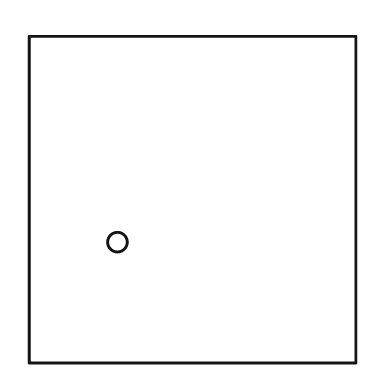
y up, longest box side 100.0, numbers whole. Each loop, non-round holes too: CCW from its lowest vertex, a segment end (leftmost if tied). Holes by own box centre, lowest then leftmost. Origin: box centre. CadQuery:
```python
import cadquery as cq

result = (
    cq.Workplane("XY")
    .moveTo(-50.0, -50.0)
    .lineTo(50.0, -50.0)
    .lineTo(50.0, 50.0)
    .lineTo(-50.0, 50.0)
    .close()
    .moveTo(-23.0, -13.0)
    .circle(3.0)
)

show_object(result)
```